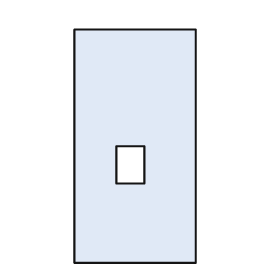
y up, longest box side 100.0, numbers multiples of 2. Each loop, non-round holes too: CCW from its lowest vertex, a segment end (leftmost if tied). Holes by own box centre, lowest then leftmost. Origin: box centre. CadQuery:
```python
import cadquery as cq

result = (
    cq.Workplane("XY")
    .moveTo(-26.0, -50.0)
    .lineTo(26.0, -50.0)
    .lineTo(26.0, 50.0)
    .lineTo(-26.0, 50.0)
    .close()
    .moveTo(-8.0, -16.0)
    .lineTo(4.0, -16.0)
    .lineTo(4.0, 0.0)
    .lineTo(-8.0, 0.0)
    .close()
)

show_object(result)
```